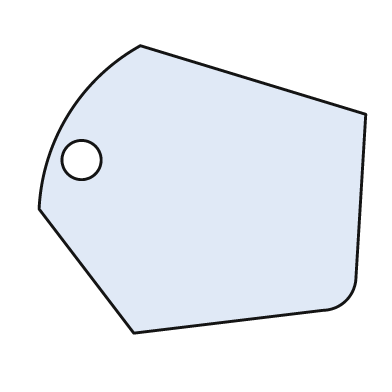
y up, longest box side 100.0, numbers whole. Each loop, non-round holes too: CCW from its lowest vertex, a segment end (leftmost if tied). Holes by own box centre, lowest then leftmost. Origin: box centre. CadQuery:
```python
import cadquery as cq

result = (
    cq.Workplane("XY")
    .moveTo(-21.0, -44.0)
    .lineTo(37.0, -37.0)
    .threePointArc((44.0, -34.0), (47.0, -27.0))
    .lineTo(50.0, 23.0)
    .lineTo(-19.0, 44.0)
    .threePointArc((-41.0, 23.0), (-50.0, -6.0))
    .close()
    .moveTo(-37.0, 9.0)
    .circle(6.0)
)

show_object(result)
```